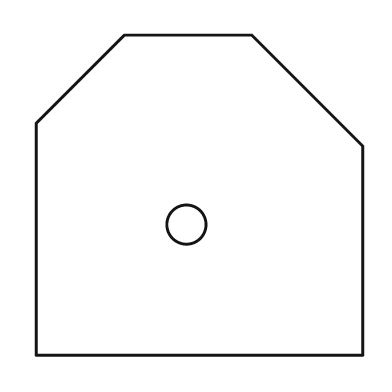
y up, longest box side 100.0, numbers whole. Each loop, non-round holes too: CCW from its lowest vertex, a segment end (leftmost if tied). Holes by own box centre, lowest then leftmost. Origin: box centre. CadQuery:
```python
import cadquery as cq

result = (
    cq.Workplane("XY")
    .moveTo(-50.0, -49.0)
    .lineTo(50.0, -49.0)
    .lineTo(50.0, 15.0)
    .lineTo(16.0, 49.0)
    .lineTo(-23.0, 49.0)
    .lineTo(-50.0, 22.0)
    .close()
    .moveTo(-4.0, -9.0)
    .circle(6.0)
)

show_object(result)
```